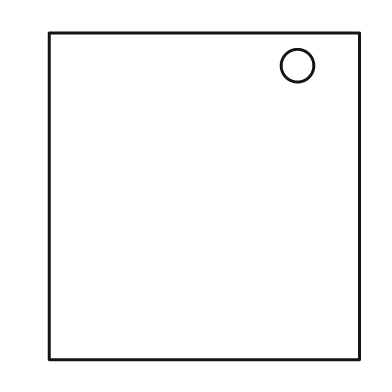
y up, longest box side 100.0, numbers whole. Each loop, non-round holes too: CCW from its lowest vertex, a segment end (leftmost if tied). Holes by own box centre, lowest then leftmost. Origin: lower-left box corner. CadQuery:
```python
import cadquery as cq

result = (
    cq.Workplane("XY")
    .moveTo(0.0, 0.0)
    .lineTo(95.0, 0.0)
    .lineTo(95.0, 100.0)
    .lineTo(0.0, 100.0)
    .close()
    .moveTo(76.0, 90.0)
    .circle(5.0)
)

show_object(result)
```